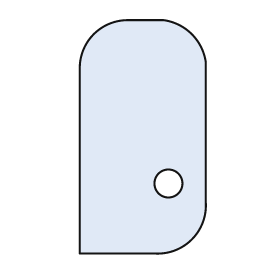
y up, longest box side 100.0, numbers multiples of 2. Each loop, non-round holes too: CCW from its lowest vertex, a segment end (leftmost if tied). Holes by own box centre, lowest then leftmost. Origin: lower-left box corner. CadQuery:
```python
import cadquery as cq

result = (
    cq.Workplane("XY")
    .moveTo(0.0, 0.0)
    .lineTo(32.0, 0.0)
    .threePointArc((48.0, 6.0), (54.0, 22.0))
    .lineTo(54.0, 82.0)
    .threePointArc((48.0, 94.0), (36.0, 100.0))
    .lineTo(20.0, 100.0)
    .threePointArc((6.0, 94.0), (0.0, 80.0))
    .close()
    .moveTo(38.0, 30.0)
    .circle(6.0)
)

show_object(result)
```